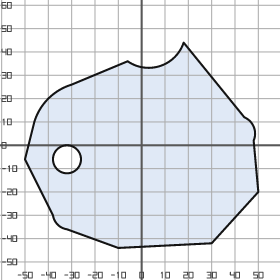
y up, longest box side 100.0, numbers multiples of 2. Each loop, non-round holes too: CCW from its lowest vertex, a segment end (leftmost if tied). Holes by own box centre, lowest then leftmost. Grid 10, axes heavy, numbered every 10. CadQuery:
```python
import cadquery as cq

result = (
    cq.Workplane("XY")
    .moveTo(-10.0, -44.0)
    .lineTo(30.0, -42.0)
    .lineTo(50.0, -20.0)
    .lineTo(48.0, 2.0)
    .threePointArc((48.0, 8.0), (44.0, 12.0))
    .lineTo(18.0, 44.0)
    .threePointArc((8.0, 34.0), (-6.0, 36.0))
    .lineTo(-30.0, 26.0)
    .threePointArc((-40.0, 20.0), (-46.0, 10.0))
    .lineTo(-50.0, -6.0)
    .lineTo(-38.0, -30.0)
    .threePointArc((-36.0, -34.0), (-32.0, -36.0))
    .close()
    .moveTo(-32.0, -6.0)
    .circle(6.0)
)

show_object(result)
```